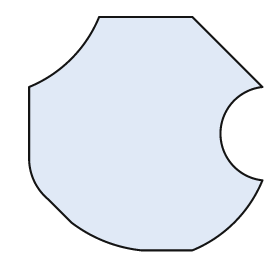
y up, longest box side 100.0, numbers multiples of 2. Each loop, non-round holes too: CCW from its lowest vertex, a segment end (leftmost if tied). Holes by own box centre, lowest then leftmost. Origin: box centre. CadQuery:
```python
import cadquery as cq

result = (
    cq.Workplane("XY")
    .moveTo(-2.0, -50.0)
    .lineTo(20.0, -50.0)
    .threePointArc((38.0, -38.0), (50.0, -20.0))
    .threePointArc((32.0, 0.0), (50.0, 20.0))
    .lineTo(20.0, 50.0)
    .lineTo(-20.0, 50.0)
    .threePointArc((-32.0, 32.0), (-50.0, 20.0))
    .lineTo(-50.0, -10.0)
    .threePointArc((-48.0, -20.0), (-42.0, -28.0))
    .lineTo(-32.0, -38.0)
    .threePointArc((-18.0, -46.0), (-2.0, -50.0))
    .close()
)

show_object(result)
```